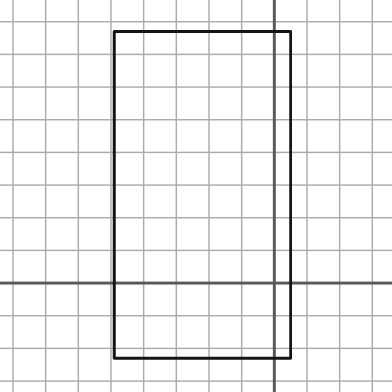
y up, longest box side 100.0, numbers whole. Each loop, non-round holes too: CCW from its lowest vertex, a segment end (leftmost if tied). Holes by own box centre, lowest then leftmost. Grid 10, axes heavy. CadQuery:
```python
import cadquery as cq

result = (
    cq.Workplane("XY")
    .moveTo(-49.0, -23.0)
    .lineTo(5.0, -23.0)
    .lineTo(5.0, 77.0)
    .lineTo(-49.0, 77.0)
    .close()
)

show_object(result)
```